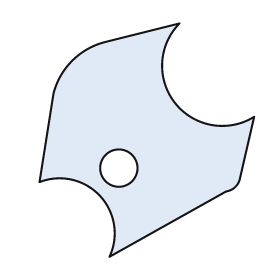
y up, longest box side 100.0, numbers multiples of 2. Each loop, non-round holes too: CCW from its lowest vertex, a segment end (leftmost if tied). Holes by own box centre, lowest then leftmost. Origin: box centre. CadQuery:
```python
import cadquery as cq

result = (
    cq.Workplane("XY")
    .moveTo(-16.0, -50.0)
    .lineTo(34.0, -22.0)
    .threePointArc((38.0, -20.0), (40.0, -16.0))
    .lineTo(46.0, 10.0)
    .threePointArc((12.0, 16.0), (14.0, 50.0))
    .lineTo(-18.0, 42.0)
    .threePointArc((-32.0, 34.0), (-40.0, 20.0))
    .lineTo(-46.0, -18.0)
    .threePointArc((-20.0, -24.0), (-16.0, -50.0))
    .close()
    .moveTo(-12.0, -12.0)
    .circle(8.0)
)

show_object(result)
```